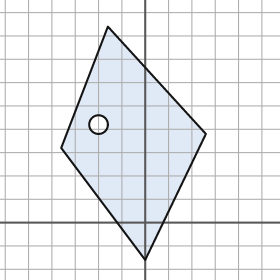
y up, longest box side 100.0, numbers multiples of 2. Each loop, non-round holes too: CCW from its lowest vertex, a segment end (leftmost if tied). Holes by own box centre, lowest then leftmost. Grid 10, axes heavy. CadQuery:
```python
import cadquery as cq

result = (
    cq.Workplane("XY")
    .moveTo(0.0, -16.0)
    .lineTo(26.0, 38.0)
    .lineTo(-16.0, 84.0)
    .lineTo(-36.0, 32.0)
    .close()
    .moveTo(-20.0, 42.0)
    .circle(4.0)
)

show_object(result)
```